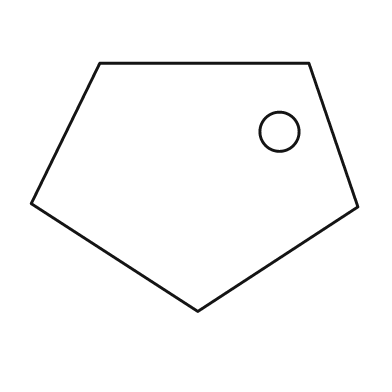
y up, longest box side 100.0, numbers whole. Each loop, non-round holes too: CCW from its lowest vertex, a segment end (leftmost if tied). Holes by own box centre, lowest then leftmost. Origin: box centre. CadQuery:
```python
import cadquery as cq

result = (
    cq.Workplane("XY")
    .moveTo(1.0, -38.0)
    .lineTo(50.0, -6.0)
    .lineTo(35.0, 38.0)
    .lineTo(-29.0, 38.0)
    .lineTo(-50.0, -5.0)
    .close()
    .moveTo(26.0, 17.0)
    .circle(6.0)
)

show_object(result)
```